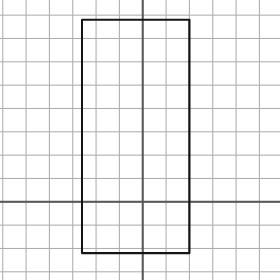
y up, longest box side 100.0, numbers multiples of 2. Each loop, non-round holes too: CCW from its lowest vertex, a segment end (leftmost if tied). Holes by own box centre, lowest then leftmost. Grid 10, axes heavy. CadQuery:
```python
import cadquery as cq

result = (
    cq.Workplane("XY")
    .moveTo(-26.0, -22.0)
    .lineTo(20.0, -22.0)
    .lineTo(20.0, 78.0)
    .lineTo(-26.0, 78.0)
    .close()
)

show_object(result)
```